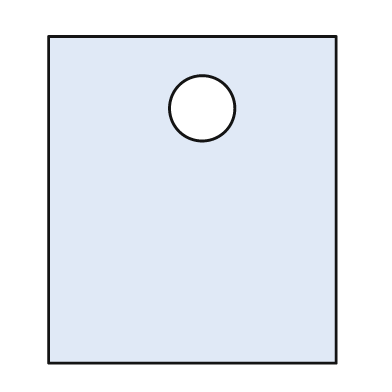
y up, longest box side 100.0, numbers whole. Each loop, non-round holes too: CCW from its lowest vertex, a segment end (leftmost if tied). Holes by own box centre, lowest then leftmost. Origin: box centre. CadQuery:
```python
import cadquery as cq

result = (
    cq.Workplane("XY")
    .moveTo(-44.0, -50.0)
    .lineTo(44.0, -50.0)
    .lineTo(44.0, 50.0)
    .lineTo(-44.0, 50.0)
    .close()
    .moveTo(3.0, 28.0)
    .circle(10.0)
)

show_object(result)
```